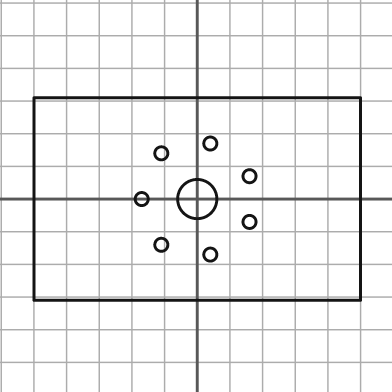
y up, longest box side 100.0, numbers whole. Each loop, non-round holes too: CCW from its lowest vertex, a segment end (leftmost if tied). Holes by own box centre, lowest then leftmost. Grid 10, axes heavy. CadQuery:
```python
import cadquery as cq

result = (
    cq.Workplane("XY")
    .moveTo(-50.0, -31.0)
    .lineTo(50.0, -31.0)
    .lineTo(50.0, 31.0)
    .lineTo(-50.0, 31.0)
    .close()
    .moveTo(4.0, -17.0)
    .circle(2.0)
    .moveTo(-11.0, -14.0)
    .circle(2.0)
    .moveTo(16.0, -7.0)
    .circle(2.0)
    .moveTo(-17.0, 0.0)
    .circle(2.0)
    .moveTo(0.0, 0.0)
    .circle(6.0)
    .moveTo(16.0, 7.0)
    .circle(2.0)
    .moveTo(-11.0, 14.0)
    .circle(2.0)
    .moveTo(4.0, 17.0)
    .circle(2.0)
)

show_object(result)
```